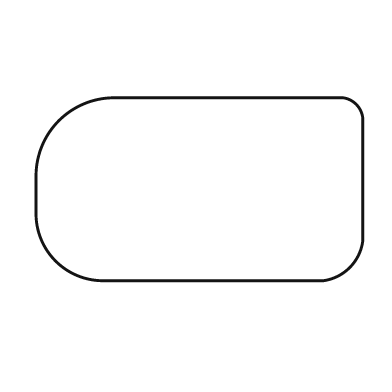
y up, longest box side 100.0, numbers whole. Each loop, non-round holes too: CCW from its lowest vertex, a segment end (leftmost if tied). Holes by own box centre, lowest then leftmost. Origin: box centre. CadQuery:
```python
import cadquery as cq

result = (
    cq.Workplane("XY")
    .moveTo(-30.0, -28.0)
    .lineTo(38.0, -28.0)
    .threePointArc((46.0, -24.0), (50.0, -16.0))
    .lineTo(50.0, 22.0)
    .threePointArc((48.0, 26.0), (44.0, 28.0))
    .lineTo(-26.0, 28.0)
    .threePointArc((-43.0, 21.0), (-50.0, 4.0))
    .lineTo(-50.0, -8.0)
    .threePointArc((-44.0, -22.0), (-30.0, -28.0))
    .close()
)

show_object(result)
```